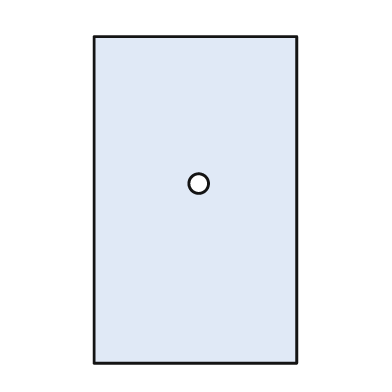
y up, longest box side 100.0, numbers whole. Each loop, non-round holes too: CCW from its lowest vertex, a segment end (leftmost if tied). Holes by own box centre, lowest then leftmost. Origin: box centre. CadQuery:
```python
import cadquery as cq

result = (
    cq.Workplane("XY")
    .moveTo(-31.0, -50.0)
    .lineTo(31.0, -50.0)
    .lineTo(31.0, 50.0)
    .lineTo(-31.0, 50.0)
    .close()
    .moveTo(1.0, 5.0)
    .circle(3.0)
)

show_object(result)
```